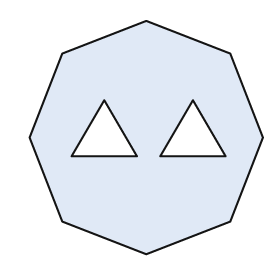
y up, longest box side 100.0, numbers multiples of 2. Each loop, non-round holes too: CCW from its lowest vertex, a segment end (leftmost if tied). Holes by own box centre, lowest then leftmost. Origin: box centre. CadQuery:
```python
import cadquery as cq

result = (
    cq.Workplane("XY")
    .moveTo(0.0, -50.0)
    .lineTo(36.0, -36.0)
    .lineTo(50.0, 0.0)
    .lineTo(36.0, 36.0)
    .lineTo(0.0, 50.0)
    .lineTo(-36.0, 36.0)
    .lineTo(-50.0, 0.0)
    .lineTo(-36.0, -36.0)
    .close()
    .moveTo(-32.0, -8.0)
    .lineTo(-4.0, -8.0)
    .lineTo(-18.0, 16.0)
    .close()
    .moveTo(6.0, -8.0)
    .lineTo(34.0, -8.0)
    .lineTo(20.0, 16.0)
    .close()
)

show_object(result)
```